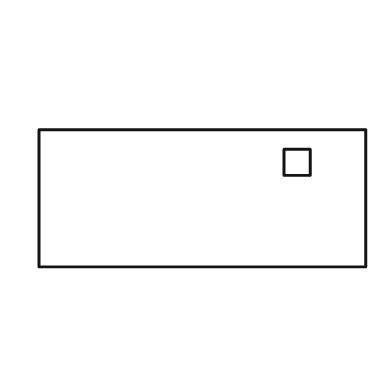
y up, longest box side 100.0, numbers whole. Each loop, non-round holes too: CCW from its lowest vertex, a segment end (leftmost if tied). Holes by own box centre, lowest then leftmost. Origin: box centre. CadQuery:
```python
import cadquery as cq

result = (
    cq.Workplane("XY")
    .moveTo(-50.0, -21.0)
    .lineTo(50.0, -21.0)
    .lineTo(50.0, 21.0)
    .lineTo(-50.0, 21.0)
    .close()
    .moveTo(25.0, 7.0)
    .lineTo(33.0, 7.0)
    .lineTo(33.0, 15.0)
    .lineTo(25.0, 15.0)
    .close()
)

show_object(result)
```